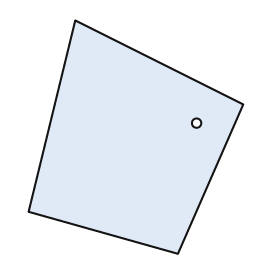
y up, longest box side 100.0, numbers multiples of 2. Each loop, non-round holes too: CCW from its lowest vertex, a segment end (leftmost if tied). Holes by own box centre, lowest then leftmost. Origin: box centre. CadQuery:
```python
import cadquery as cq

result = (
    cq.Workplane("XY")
    .moveTo(18.0, -50.0)
    .lineTo(46.0, 14.0)
    .lineTo(-26.0, 50.0)
    .lineTo(-46.0, -32.0)
    .close()
    .moveTo(26.0, 6.0)
    .circle(2.0)
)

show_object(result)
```